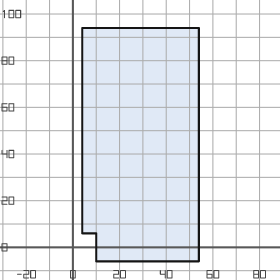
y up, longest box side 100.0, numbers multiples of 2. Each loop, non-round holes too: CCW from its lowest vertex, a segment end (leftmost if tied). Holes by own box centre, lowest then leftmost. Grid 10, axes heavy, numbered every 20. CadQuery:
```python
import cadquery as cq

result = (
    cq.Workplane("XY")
    .moveTo(10.0, -6.0)
    .lineTo(54.0, -6.0)
    .lineTo(54.0, 94.0)
    .lineTo(4.0, 94.0)
    .lineTo(4.0, 6.0)
    .lineTo(10.0, 6.0)
    .close()
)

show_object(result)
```